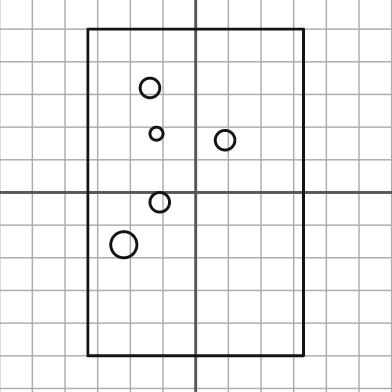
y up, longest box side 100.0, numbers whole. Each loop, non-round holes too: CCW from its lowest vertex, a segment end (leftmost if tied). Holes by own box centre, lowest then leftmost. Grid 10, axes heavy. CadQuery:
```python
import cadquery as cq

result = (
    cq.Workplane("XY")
    .moveTo(-33.0, -50.0)
    .lineTo(33.0, -50.0)
    .lineTo(33.0, 50.0)
    .lineTo(-33.0, 50.0)
    .close()
    .moveTo(-22.0, -16.0)
    .circle(4.0)
    .moveTo(-11.0, -3.0)
    .circle(3.0)
    .moveTo(9.0, 16.0)
    .circle(3.0)
    .moveTo(-12.0, 18.0)
    .circle(2.0)
    .moveTo(-14.0, 32.0)
    .circle(3.0)
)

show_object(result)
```